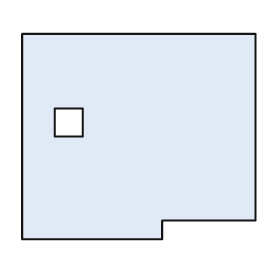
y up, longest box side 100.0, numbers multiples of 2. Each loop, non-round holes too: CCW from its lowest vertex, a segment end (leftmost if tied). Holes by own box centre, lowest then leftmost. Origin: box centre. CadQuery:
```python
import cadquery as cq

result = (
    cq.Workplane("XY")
    .moveTo(-50.0, -44.0)
    .lineTo(10.0, -44.0)
    .lineTo(10.0, -36.0)
    .lineTo(50.0, -36.0)
    .lineTo(50.0, 44.0)
    .lineTo(-50.0, 44.0)
    .close()
    .moveTo(-36.0, 0.0)
    .lineTo(-24.0, 0.0)
    .lineTo(-24.0, 12.0)
    .lineTo(-36.0, 12.0)
    .close()
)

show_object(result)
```